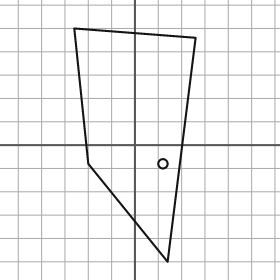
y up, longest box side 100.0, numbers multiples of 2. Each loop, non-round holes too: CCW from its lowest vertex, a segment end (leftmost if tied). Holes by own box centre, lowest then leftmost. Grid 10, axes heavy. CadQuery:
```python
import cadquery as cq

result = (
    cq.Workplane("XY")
    .moveTo(14.0, -50.0)
    .lineTo(26.0, 46.0)
    .lineTo(-26.0, 50.0)
    .lineTo(-20.0, -8.0)
    .close()
    .moveTo(12.0, -8.0)
    .circle(2.0)
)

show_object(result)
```